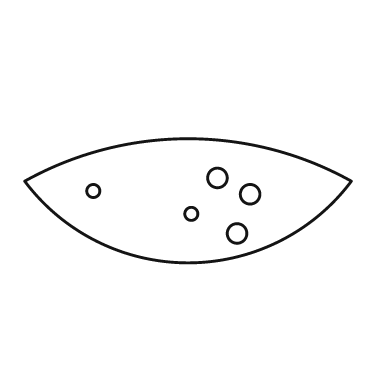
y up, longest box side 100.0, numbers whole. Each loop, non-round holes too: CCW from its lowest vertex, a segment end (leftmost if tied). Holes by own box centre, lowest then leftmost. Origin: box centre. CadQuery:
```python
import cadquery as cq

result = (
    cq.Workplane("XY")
    .moveTo(-50.0, 6.0)
    .threePointArc((0.0, -19.0), (50.0, 6.0))
    .threePointArc((0.0, 19.0), (-50.0, 6.0))
    .close()
    .moveTo(15.0, -10.0)
    .circle(3.0)
    .moveTo(1.0, -4.0)
    .circle(2.0)
    .moveTo(19.0, 2.0)
    .circle(3.0)
    .moveTo(-29.0, 3.0)
    .circle(2.0)
    .moveTo(9.0, 7.0)
    .circle(3.0)
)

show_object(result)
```